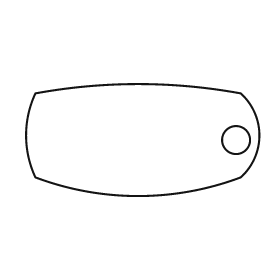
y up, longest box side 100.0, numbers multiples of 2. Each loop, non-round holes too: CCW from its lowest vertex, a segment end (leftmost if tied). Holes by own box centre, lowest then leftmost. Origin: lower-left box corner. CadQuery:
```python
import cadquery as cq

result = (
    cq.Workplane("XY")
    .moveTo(4.0, 8.0)
    .threePointArc((48.0, 0.0), (92.0, 8.0))
    .threePointArc((100.0, 26.0), (92.0, 44.0))
    .threePointArc((48.0, 48.0), (4.0, 44.0))
    .threePointArc((0.0, 26.0), (4.0, 8.0))
    .close()
    .moveTo(90.0, 24.0)
    .circle(6.0)
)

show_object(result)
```